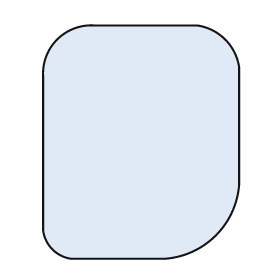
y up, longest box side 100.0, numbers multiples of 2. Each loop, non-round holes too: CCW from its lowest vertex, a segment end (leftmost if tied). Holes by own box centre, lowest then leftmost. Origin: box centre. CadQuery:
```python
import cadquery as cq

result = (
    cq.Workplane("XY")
    .moveTo(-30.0, -50.0)
    .lineTo(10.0, -50.0)
    .threePointArc((32.0, -40.0), (42.0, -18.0))
    .lineTo(42.0, 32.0)
    .threePointArc((36.0, 44.0), (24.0, 50.0))
    .lineTo(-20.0, 50.0)
    .threePointArc((-36.0, 44.0), (-42.0, 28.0))
    .lineTo(-42.0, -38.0)
    .threePointArc((-38.0, -46.0), (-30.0, -50.0))
    .close()
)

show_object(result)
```